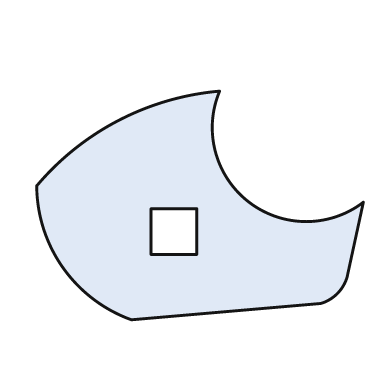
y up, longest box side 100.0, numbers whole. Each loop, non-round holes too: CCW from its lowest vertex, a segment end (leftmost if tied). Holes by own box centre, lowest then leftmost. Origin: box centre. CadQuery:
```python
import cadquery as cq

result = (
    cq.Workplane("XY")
    .moveTo(-21.0, -35.0)
    .lineTo(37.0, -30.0)
    .threePointArc((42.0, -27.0), (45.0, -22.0))
    .lineTo(50.0, 1.0)
    .threePointArc((15.0, 1.0), (6.0, 35.0))
    .threePointArc((-25.0, 26.0), (-50.0, 6.0))
    .threePointArc((-42.0, -19.0), (-21.0, -35.0))
    .close()
    .moveTo(-15.0, -15.0)
    .lineTo(-1.0, -15.0)
    .lineTo(-1.0, -1.0)
    .lineTo(-15.0, -1.0)
    .close()
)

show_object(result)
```